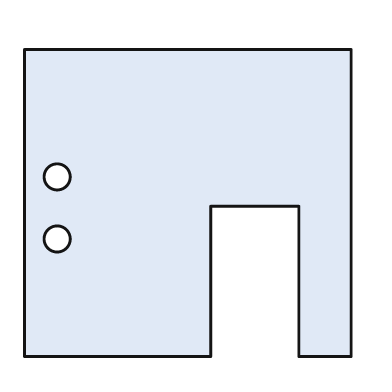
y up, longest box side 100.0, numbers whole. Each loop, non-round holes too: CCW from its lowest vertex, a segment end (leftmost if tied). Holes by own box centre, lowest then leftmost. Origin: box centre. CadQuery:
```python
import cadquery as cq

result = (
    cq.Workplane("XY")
    .moveTo(-50.0, -47.0)
    .lineTo(7.0, -47.0)
    .lineTo(7.0, -1.0)
    .lineTo(34.0, -1.0)
    .lineTo(34.0, -47.0)
    .lineTo(50.0, -47.0)
    .lineTo(50.0, 47.0)
    .lineTo(-50.0, 47.0)
    .close()
    .moveTo(-40.0, -11.0)
    .circle(4.0)
    .moveTo(-40.0, 8.0)
    .circle(4.0)
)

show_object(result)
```